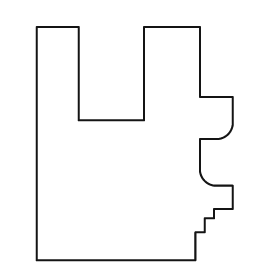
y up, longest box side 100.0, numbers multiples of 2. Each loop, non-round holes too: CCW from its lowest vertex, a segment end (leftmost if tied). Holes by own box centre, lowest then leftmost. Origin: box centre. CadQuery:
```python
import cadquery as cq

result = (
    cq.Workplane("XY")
    .moveTo(-42.0, -50.0)
    .lineTo(26.0, -50.0)
    .lineTo(26.0, -38.0)
    .lineTo(30.0, -38.0)
    .lineTo(30.0, -32.0)
    .lineTo(34.0, -32.0)
    .lineTo(34.0, -28.0)
    .lineTo(42.0, -28.0)
    .lineTo(42.0, -18.0)
    .lineTo(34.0, -18.0)
    .threePointArc((30.0, -16.0), (28.0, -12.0))
    .lineTo(28.0, 2.0)
    .lineTo(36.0, 2.0)
    .threePointArc((40.0, 4.0), (42.0, 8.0))
    .lineTo(42.0, 20.0)
    .lineTo(28.0, 20.0)
    .lineTo(28.0, 50.0)
    .lineTo(4.0, 50.0)
    .lineTo(4.0, 10.0)
    .lineTo(-24.0, 10.0)
    .lineTo(-24.0, 50.0)
    .lineTo(-42.0, 50.0)
    .close()
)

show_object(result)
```